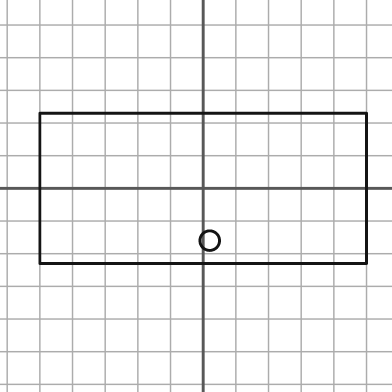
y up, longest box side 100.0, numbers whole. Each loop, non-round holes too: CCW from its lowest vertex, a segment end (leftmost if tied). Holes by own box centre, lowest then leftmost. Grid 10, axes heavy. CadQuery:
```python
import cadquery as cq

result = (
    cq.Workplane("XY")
    .moveTo(-50.0, -23.0)
    .lineTo(50.0, -23.0)
    .lineTo(50.0, 23.0)
    .lineTo(-50.0, 23.0)
    .close()
    .moveTo(2.0, -16.0)
    .circle(3.0)
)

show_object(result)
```